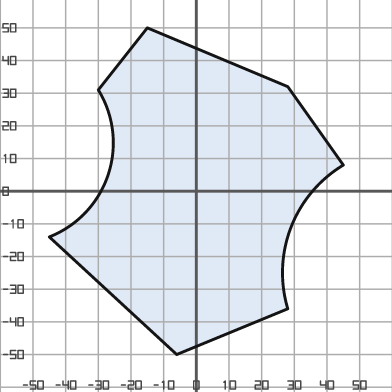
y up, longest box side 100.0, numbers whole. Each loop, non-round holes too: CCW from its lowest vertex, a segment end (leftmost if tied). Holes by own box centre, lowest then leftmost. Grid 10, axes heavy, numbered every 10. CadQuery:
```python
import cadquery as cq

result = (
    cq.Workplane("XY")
    .moveTo(-6.0, -50.0)
    .lineTo(28.0, -36.0)
    .threePointArc((29.0, -11.0), (45.0, 8.0))
    .lineTo(28.0, 32.0)
    .lineTo(-15.0, 50.0)
    .lineTo(-30.0, 31.0)
    .threePointArc((-27.0, 5.0), (-45.0, -14.0))
    .close()
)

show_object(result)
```